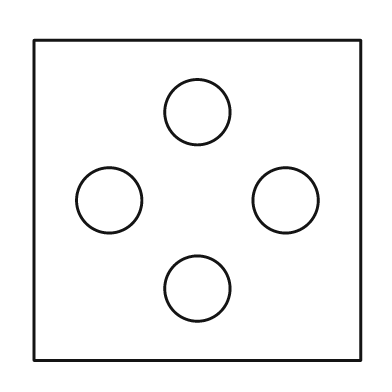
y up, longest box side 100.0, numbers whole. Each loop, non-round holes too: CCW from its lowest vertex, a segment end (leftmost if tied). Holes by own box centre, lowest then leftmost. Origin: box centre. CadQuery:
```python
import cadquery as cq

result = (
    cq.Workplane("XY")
    .moveTo(-50.0, -49.0)
    .lineTo(50.0, -49.0)
    .lineTo(50.0, 49.0)
    .lineTo(-50.0, 49.0)
    .close()
    .moveTo(0.0, -27.0)
    .circle(10.0)
    .moveTo(-27.0, 0.0)
    .circle(10.0)
    .moveTo(27.0, 0.0)
    .circle(10.0)
    .moveTo(0.0, 27.0)
    .circle(10.0)
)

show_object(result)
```